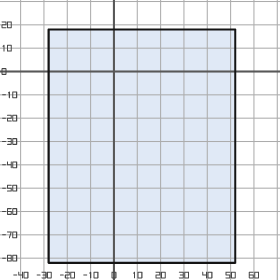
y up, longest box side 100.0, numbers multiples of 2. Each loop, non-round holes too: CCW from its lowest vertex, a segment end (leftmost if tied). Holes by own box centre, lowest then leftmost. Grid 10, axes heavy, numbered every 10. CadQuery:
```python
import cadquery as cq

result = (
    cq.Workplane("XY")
    .moveTo(-28.0, -82.0)
    .lineTo(52.0, -82.0)
    .lineTo(52.0, 18.0)
    .lineTo(-28.0, 18.0)
    .close()
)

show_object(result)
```